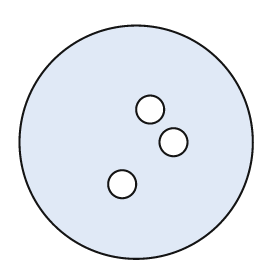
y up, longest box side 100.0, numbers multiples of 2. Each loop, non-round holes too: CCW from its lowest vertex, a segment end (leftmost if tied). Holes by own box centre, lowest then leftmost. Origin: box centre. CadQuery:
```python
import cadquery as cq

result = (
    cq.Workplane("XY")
    .moveTo(0.0, 0.0)
    .circle(50.0)
    .moveTo(-6.0, -18.0)
    .circle(6.0)
    .moveTo(16.0, 0.0)
    .circle(6.0)
    .moveTo(6.0, 14.0)
    .circle(6.0)
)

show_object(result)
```